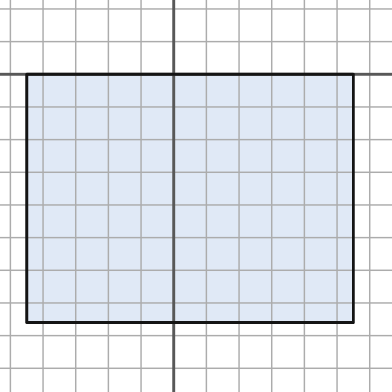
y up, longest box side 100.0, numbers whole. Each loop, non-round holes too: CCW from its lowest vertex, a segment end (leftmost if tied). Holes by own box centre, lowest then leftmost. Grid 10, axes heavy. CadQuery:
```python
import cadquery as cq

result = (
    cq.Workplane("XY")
    .moveTo(-45.0, -76.0)
    .lineTo(55.0, -76.0)
    .lineTo(55.0, 0.0)
    .lineTo(-45.0, 0.0)
    .close()
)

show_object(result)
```